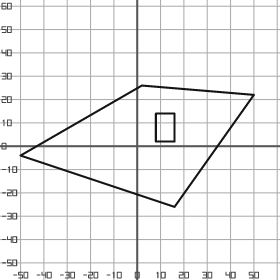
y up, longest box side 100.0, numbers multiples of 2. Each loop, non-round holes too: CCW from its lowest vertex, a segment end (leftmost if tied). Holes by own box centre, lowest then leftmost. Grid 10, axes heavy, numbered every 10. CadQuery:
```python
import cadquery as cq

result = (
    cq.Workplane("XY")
    .moveTo(16.0, -26.0)
    .lineTo(50.0, 22.0)
    .lineTo(2.0, 26.0)
    .lineTo(-50.0, -4.0)
    .close()
    .moveTo(8.0, 2.0)
    .lineTo(16.0, 2.0)
    .lineTo(16.0, 14.0)
    .lineTo(8.0, 14.0)
    .close()
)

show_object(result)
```